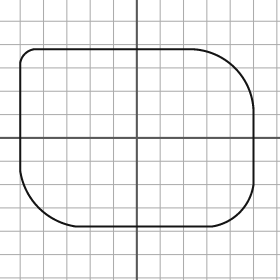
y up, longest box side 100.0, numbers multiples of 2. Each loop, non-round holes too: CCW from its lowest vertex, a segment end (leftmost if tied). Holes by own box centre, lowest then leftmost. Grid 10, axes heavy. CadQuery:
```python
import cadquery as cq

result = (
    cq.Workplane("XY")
    .moveTo(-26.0, -38.0)
    .lineTo(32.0, -38.0)
    .threePointArc((44.0, -32.0), (50.0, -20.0))
    .lineTo(50.0, 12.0)
    .threePointArc((42.0, 30.0), (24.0, 38.0))
    .lineTo(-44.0, 38.0)
    .threePointArc((-48.0, 36.0), (-50.0, 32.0))
    .lineTo(-50.0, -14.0)
    .threePointArc((-42.0, -30.0), (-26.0, -38.0))
    .close()
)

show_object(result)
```